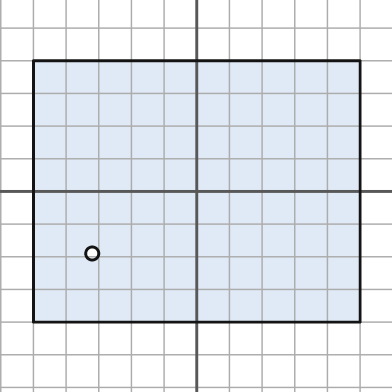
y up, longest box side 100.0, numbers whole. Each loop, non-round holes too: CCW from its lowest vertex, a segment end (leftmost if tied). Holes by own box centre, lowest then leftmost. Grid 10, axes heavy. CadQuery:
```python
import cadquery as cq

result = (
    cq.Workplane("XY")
    .moveTo(-50.0, -40.0)
    .lineTo(50.0, -40.0)
    .lineTo(50.0, 40.0)
    .lineTo(-50.0, 40.0)
    .close()
    .moveTo(-32.0, -19.0)
    .circle(2.0)
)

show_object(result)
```